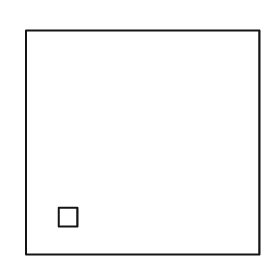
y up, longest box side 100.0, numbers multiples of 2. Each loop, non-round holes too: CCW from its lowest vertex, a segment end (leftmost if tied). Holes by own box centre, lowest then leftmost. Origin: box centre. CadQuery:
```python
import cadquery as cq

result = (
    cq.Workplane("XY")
    .moveTo(-50.0, -48.0)
    .lineTo(50.0, -48.0)
    .lineTo(50.0, 48.0)
    .lineTo(-50.0, 48.0)
    .close()
    .moveTo(-36.0, -36.0)
    .lineTo(-28.0, -36.0)
    .lineTo(-28.0, -28.0)
    .lineTo(-36.0, -28.0)
    .close()
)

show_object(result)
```